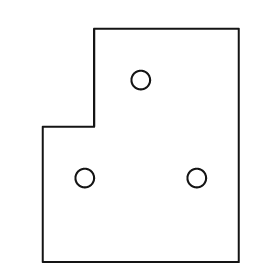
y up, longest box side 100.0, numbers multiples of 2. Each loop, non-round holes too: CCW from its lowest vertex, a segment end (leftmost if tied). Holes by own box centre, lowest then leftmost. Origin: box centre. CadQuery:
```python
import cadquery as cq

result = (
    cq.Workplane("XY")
    .moveTo(-42.0, -50.0)
    .lineTo(42.0, -50.0)
    .lineTo(42.0, 50.0)
    .lineTo(-20.0, 50.0)
    .lineTo(-20.0, 8.0)
    .lineTo(-42.0, 8.0)
    .close()
    .moveTo(-24.0, -14.0)
    .circle(4.0)
    .moveTo(24.0, -14.0)
    .circle(4.0)
    .moveTo(0.0, 28.0)
    .circle(4.0)
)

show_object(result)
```